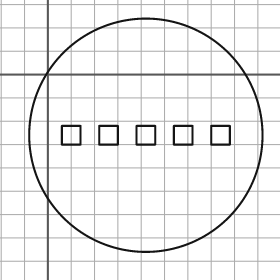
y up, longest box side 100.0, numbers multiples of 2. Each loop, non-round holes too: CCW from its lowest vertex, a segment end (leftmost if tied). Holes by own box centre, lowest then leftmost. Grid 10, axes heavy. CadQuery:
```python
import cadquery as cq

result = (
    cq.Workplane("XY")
    .moveTo(42.0, -26.0)
    .circle(50.0)
    .moveTo(6.0, -30.0)
    .lineTo(14.0, -30.0)
    .lineTo(14.0, -22.0)
    .lineTo(6.0, -22.0)
    .close()
    .moveTo(22.0, -30.0)
    .lineTo(30.0, -30.0)
    .lineTo(30.0, -22.0)
    .lineTo(22.0, -22.0)
    .close()
    .moveTo(38.0, -30.0)
    .lineTo(46.0, -30.0)
    .lineTo(46.0, -22.0)
    .lineTo(38.0, -22.0)
    .close()
    .moveTo(54.0, -30.0)
    .lineTo(62.0, -30.0)
    .lineTo(62.0, -22.0)
    .lineTo(54.0, -22.0)
    .close()
    .moveTo(70.0, -30.0)
    .lineTo(78.0, -30.0)
    .lineTo(78.0, -22.0)
    .lineTo(70.0, -22.0)
    .close()
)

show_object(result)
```